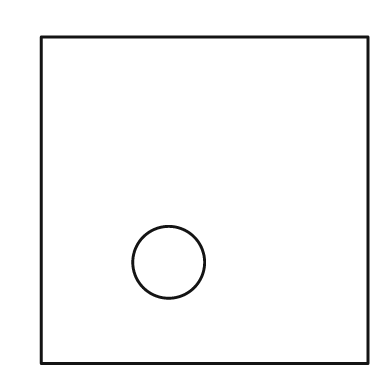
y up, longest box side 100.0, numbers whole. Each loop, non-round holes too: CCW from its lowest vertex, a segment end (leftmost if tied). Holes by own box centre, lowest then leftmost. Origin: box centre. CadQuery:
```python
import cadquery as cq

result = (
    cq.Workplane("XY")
    .moveTo(-50.0, -50.0)
    .lineTo(50.0, -50.0)
    .lineTo(50.0, 50.0)
    .lineTo(-50.0, 50.0)
    .close()
    .moveTo(-11.0, -19.0)
    .circle(11.0)
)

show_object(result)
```